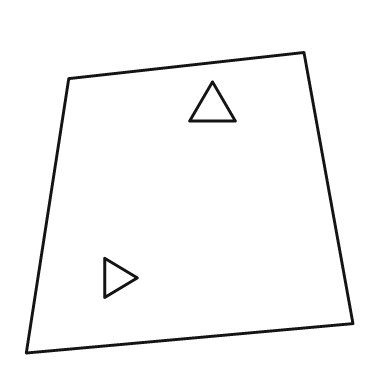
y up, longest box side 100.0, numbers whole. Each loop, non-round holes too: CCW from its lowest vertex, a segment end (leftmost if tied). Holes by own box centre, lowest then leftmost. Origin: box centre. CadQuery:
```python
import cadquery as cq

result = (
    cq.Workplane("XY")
    .moveTo(-50.0, -46.0)
    .lineTo(50.0, -37.0)
    .lineTo(35.0, 46.0)
    .lineTo(-37.0, 38.0)
    .close()
    .moveTo(-26.0, -29.0)
    .lineTo(-16.0, -23.0)
    .lineTo(-26.0, -17.0)
    .close()
    .moveTo(0.0, 25.0)
    .lineTo(14.0, 25.0)
    .lineTo(7.0, 37.0)
    .close()
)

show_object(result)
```